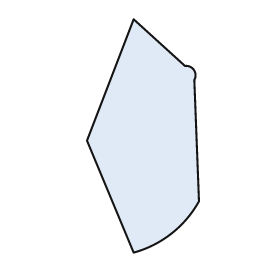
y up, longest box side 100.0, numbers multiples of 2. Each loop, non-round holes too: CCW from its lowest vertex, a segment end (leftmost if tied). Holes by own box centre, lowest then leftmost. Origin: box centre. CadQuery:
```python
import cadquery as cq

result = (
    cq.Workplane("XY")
    .moveTo(-4.0, -50.0)
    .threePointArc((12.0, -42.0), (24.0, -28.0))
    .lineTo(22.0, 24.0)
    .threePointArc((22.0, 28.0), (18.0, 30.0))
    .lineTo(-4.0, 50.0)
    .lineTo(-24.0, -2.0)
    .close()
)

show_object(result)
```